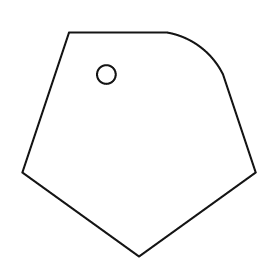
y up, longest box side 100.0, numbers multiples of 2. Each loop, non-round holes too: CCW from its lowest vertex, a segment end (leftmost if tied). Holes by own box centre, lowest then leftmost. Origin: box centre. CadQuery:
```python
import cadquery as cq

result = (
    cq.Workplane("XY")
    .moveTo(0.0, -48.0)
    .lineTo(50.0, -12.0)
    .lineTo(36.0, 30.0)
    .threePointArc((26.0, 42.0), (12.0, 48.0))
    .lineTo(-30.0, 48.0)
    .lineTo(-50.0, -12.0)
    .close()
    .moveTo(-14.0, 30.0)
    .circle(4.0)
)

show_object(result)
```